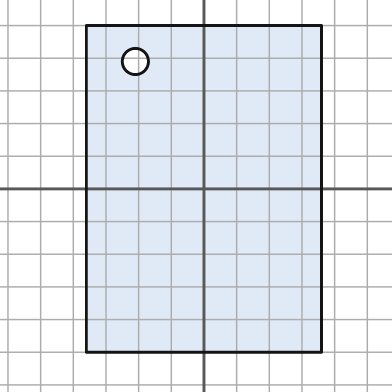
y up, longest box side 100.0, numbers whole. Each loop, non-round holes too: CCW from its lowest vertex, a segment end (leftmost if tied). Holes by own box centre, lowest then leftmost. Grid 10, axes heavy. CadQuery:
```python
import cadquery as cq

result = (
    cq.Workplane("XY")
    .moveTo(-36.0, -50.0)
    .lineTo(36.0, -50.0)
    .lineTo(36.0, 50.0)
    .lineTo(-36.0, 50.0)
    .close()
    .moveTo(-21.0, 39.0)
    .circle(4.0)
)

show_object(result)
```